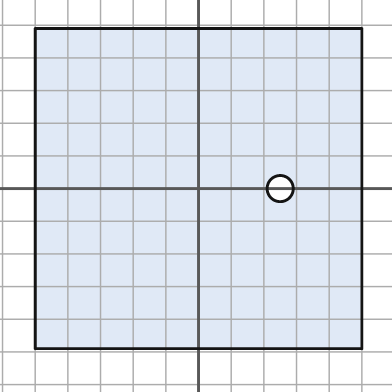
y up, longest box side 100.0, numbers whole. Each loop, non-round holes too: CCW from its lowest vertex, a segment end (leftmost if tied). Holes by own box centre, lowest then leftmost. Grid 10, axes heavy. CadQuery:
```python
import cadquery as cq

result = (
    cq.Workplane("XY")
    .moveTo(-50.0, -49.0)
    .lineTo(50.0, -49.0)
    .lineTo(50.0, 49.0)
    .lineTo(-50.0, 49.0)
    .close()
    .moveTo(25.0, 0.0)
    .circle(4.0)
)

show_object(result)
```